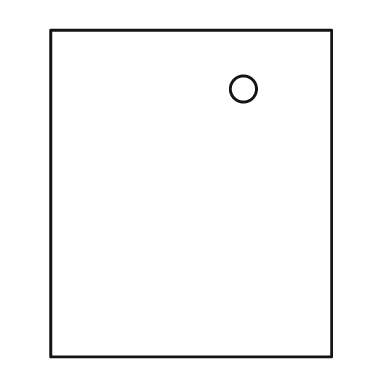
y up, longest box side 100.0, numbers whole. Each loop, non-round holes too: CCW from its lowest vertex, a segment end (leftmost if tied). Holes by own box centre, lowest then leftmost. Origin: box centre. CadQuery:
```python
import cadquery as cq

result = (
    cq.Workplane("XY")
    .moveTo(-43.0, -50.0)
    .lineTo(43.0, -50.0)
    .lineTo(43.0, 50.0)
    .lineTo(-43.0, 50.0)
    .close()
    .moveTo(16.0, 32.0)
    .circle(4.0)
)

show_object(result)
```